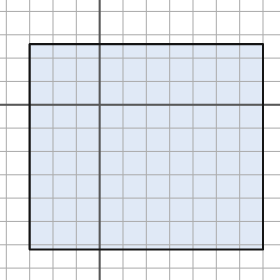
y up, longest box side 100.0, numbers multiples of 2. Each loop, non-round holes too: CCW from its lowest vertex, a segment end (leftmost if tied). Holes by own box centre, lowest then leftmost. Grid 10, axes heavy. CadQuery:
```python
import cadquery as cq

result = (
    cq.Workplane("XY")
    .moveTo(-30.0, -62.0)
    .lineTo(70.0, -62.0)
    .lineTo(70.0, 26.0)
    .lineTo(-30.0, 26.0)
    .close()
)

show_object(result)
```